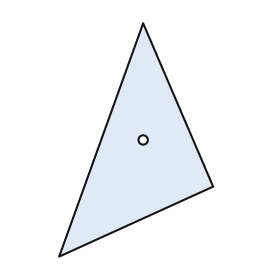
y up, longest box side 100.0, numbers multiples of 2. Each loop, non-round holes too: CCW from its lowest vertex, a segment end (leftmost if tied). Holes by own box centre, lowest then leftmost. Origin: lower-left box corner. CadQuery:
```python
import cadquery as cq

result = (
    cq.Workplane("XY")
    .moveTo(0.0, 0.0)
    .lineTo(66.0, 30.0)
    .lineTo(36.0, 100.0)
    .close()
    .moveTo(36.0, 50.0)
    .circle(2.0)
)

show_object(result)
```